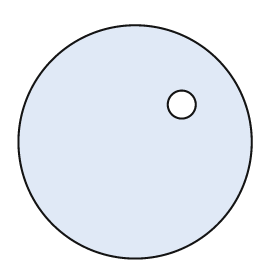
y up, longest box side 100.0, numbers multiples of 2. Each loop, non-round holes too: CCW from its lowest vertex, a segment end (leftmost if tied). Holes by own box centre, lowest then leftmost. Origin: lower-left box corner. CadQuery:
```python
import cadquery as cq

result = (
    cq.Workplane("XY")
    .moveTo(50.0, 50.0)
    .circle(50.0)
    .moveTo(70.0, 66.0)
    .circle(6.0)
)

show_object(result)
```